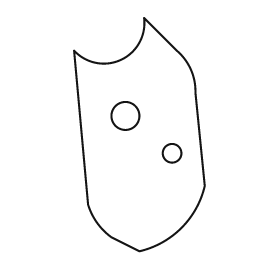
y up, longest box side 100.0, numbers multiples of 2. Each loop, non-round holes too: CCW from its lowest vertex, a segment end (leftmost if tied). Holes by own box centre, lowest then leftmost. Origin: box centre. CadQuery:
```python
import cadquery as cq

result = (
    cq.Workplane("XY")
    .moveTo(0.0, -50.0)
    .threePointArc((18.0, -40.0), (28.0, -22.0))
    .lineTo(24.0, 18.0)
    .threePointArc((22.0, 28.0), (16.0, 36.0))
    .lineTo(2.0, 50.0)
    .threePointArc((-8.0, 32.0), (-28.0, 36.0))
    .lineTo(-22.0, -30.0)
    .threePointArc((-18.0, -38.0), (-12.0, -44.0))
    .close()
    .moveTo(14.0, -8.0)
    .circle(4.0)
    .moveTo(-6.0, 8.0)
    .circle(6.0)
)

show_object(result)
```